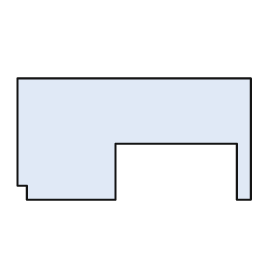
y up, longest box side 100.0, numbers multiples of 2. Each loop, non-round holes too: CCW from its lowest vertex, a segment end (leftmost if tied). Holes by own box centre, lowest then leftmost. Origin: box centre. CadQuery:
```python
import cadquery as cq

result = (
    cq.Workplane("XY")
    .moveTo(-46.0, -26.0)
    .lineTo(-8.0, -26.0)
    .lineTo(-8.0, -2.0)
    .lineTo(44.0, -2.0)
    .lineTo(44.0, -26.0)
    .lineTo(50.0, -26.0)
    .lineTo(50.0, 26.0)
    .lineTo(-50.0, 26.0)
    .lineTo(-50.0, -20.0)
    .lineTo(-46.0, -20.0)
    .close()
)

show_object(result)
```